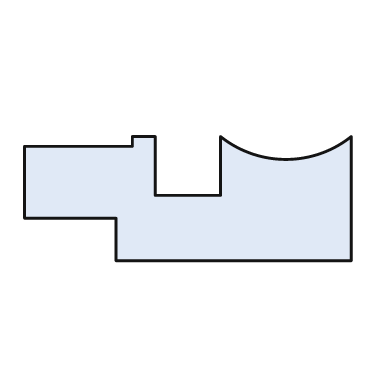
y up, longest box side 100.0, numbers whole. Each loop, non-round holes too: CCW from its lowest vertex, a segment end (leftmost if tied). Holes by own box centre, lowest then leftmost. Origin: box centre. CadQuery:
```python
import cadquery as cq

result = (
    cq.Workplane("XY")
    .moveTo(-22.0, -19.0)
    .lineTo(50.0, -19.0)
    .lineTo(50.0, 19.0)
    .threePointArc((30.0, 12.0), (10.0, 19.0))
    .lineTo(10.0, 1.0)
    .lineTo(-10.0, 1.0)
    .lineTo(-10.0, 19.0)
    .lineTo(-17.0, 19.0)
    .lineTo(-17.0, 16.0)
    .lineTo(-50.0, 16.0)
    .lineTo(-50.0, -6.0)
    .lineTo(-22.0, -6.0)
    .close()
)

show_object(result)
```